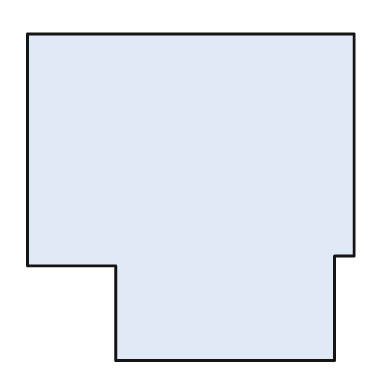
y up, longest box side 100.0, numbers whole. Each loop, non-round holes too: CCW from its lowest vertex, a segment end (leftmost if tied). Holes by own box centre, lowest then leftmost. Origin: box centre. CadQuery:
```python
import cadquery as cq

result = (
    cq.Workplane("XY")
    .moveTo(-23.0, -50.0)
    .lineTo(44.0, -50.0)
    .lineTo(44.0, -18.0)
    .lineTo(50.0, -18.0)
    .lineTo(50.0, 50.0)
    .lineTo(-50.0, 50.0)
    .lineTo(-50.0, -21.0)
    .lineTo(-23.0, -21.0)
    .close()
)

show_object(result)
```